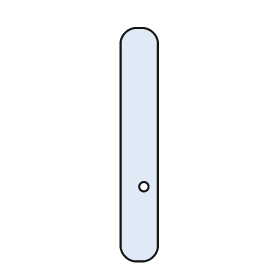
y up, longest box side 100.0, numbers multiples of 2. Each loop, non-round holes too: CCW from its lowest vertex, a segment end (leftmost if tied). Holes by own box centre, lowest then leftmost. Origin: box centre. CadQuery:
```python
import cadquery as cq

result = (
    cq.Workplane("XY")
    .moveTo(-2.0, -50.0)
    .lineTo(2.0, -50.0)
    .threePointArc((6.0, -48.0), (8.0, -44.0))
    .lineTo(8.0, 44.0)
    .threePointArc((6.0, 48.0), (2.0, 50.0))
    .lineTo(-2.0, 50.0)
    .threePointArc((-6.0, 48.0), (-8.0, 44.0))
    .lineTo(-8.0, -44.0)
    .threePointArc((-6.0, -48.0), (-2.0, -50.0))
    .close()
    .moveTo(2.0, -18.0)
    .circle(2.0)
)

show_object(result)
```